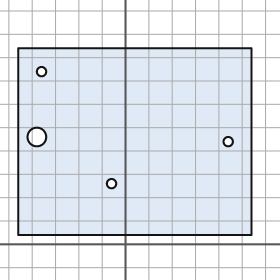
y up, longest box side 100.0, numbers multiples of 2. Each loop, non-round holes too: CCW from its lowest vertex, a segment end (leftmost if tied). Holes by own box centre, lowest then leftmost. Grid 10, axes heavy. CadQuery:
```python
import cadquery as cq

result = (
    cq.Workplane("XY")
    .moveTo(-46.0, 4.0)
    .lineTo(54.0, 4.0)
    .lineTo(54.0, 84.0)
    .lineTo(-46.0, 84.0)
    .close()
    .moveTo(-6.0, 26.0)
    .circle(2.0)
    .moveTo(44.0, 44.0)
    .circle(2.0)
    .moveTo(-38.0, 46.0)
    .circle(4.0)
    .moveTo(-36.0, 74.0)
    .circle(2.0)
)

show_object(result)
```